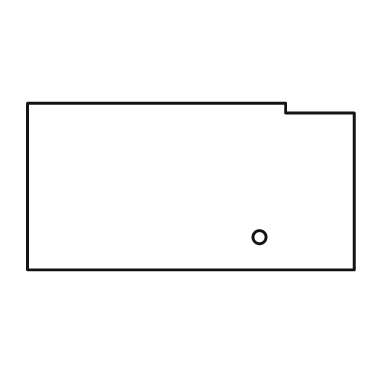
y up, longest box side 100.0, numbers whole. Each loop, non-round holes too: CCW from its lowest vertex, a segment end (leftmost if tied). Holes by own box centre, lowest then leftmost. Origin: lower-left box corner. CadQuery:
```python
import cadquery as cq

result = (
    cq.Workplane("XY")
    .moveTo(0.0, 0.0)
    .lineTo(100.0, 0.0)
    .lineTo(100.0, 48.0)
    .lineTo(79.0, 48.0)
    .lineTo(79.0, 51.0)
    .lineTo(0.0, 51.0)
    .close()
    .moveTo(71.0, 10.0)
    .circle(2.0)
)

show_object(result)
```